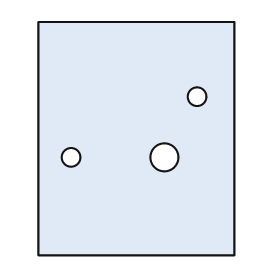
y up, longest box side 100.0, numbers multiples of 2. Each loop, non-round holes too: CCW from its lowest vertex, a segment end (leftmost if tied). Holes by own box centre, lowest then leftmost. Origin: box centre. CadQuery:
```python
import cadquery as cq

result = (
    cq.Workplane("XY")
    .moveTo(-42.0, -50.0)
    .lineTo(42.0, -50.0)
    .lineTo(42.0, 50.0)
    .lineTo(-42.0, 50.0)
    .close()
    .moveTo(-28.0, -8.0)
    .circle(4.0)
    .moveTo(12.0, -8.0)
    .circle(6.0)
    .moveTo(26.0, 18.0)
    .circle(4.0)
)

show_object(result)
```